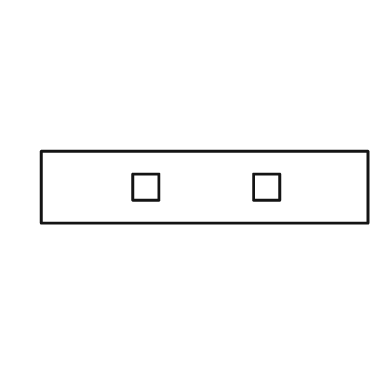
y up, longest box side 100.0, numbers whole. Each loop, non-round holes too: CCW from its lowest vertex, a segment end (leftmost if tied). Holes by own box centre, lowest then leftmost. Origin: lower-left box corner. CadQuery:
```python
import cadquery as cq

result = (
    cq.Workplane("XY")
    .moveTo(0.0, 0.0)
    .lineTo(100.0, 0.0)
    .lineTo(100.0, 22.0)
    .lineTo(0.0, 22.0)
    .close()
    .moveTo(28.0, 7.0)
    .lineTo(36.0, 7.0)
    .lineTo(36.0, 15.0)
    .lineTo(28.0, 15.0)
    .close()
    .moveTo(65.0, 7.0)
    .lineTo(73.0, 7.0)
    .lineTo(73.0, 15.0)
    .lineTo(65.0, 15.0)
    .close()
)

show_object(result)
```